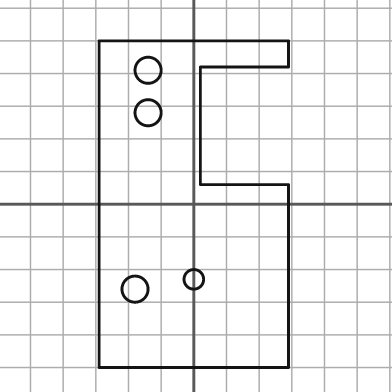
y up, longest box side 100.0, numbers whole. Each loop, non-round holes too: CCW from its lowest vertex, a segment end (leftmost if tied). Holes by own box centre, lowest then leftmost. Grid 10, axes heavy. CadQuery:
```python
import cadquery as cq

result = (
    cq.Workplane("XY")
    .moveTo(-29.0, -50.0)
    .lineTo(29.0, -50.0)
    .lineTo(29.0, 6.0)
    .lineTo(2.0, 6.0)
    .lineTo(2.0, 42.0)
    .lineTo(29.0, 42.0)
    .lineTo(29.0, 50.0)
    .lineTo(-29.0, 50.0)
    .close()
    .moveTo(-18.0, -26.0)
    .circle(4.0)
    .moveTo(0.0, -23.0)
    .circle(3.0)
    .moveTo(-14.0, 28.0)
    .circle(4.0)
    .moveTo(-14.0, 41.0)
    .circle(4.0)
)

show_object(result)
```